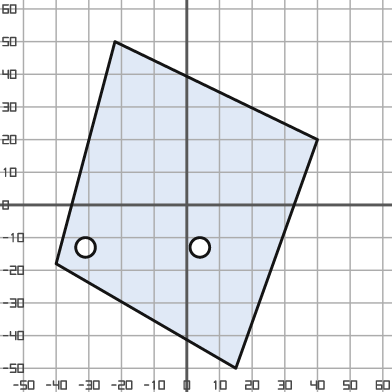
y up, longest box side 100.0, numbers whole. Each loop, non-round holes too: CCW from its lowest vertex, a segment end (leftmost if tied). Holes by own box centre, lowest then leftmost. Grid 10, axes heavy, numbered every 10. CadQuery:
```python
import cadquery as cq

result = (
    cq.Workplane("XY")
    .moveTo(15.0, -50.0)
    .lineTo(40.0, 20.0)
    .lineTo(-22.0, 50.0)
    .lineTo(-40.0, -18.0)
    .close()
    .moveTo(-31.0, -13.0)
    .circle(3.0)
    .moveTo(4.0, -13.0)
    .circle(3.0)
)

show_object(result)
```